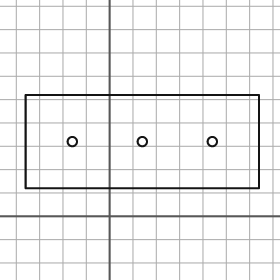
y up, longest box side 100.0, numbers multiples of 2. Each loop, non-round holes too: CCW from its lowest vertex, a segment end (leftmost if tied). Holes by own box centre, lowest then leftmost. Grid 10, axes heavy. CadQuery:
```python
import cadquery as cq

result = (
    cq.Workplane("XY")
    .moveTo(-36.0, 12.0)
    .lineTo(64.0, 12.0)
    .lineTo(64.0, 52.0)
    .lineTo(-36.0, 52.0)
    .close()
    .moveTo(-16.0, 32.0)
    .circle(2.0)
    .moveTo(14.0, 32.0)
    .circle(2.0)
    .moveTo(44.0, 32.0)
    .circle(2.0)
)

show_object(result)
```